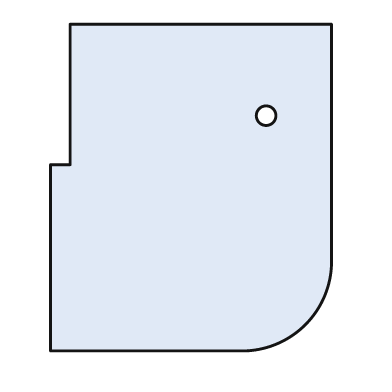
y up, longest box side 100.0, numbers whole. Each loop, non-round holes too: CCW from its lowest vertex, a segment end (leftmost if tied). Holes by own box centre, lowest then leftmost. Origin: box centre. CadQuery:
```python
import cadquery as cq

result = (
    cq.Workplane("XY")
    .moveTo(-43.0, -50.0)
    .lineTo(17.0, -50.0)
    .threePointArc((35.0, -42.0), (43.0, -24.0))
    .lineTo(43.0, 50.0)
    .lineTo(-37.0, 50.0)
    .lineTo(-37.0, 7.0)
    .lineTo(-43.0, 7.0)
    .close()
    .moveTo(23.0, 22.0)
    .circle(3.0)
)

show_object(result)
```